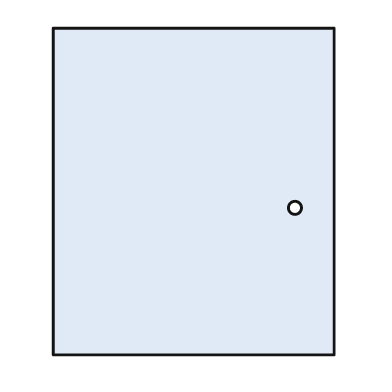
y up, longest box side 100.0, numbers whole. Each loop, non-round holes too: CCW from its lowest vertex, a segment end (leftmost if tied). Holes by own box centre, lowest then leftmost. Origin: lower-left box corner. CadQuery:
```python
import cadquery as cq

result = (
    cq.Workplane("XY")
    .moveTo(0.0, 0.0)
    .lineTo(86.0, 0.0)
    .lineTo(86.0, 100.0)
    .lineTo(0.0, 100.0)
    .close()
    .moveTo(74.0, 45.0)
    .circle(2.0)
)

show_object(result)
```